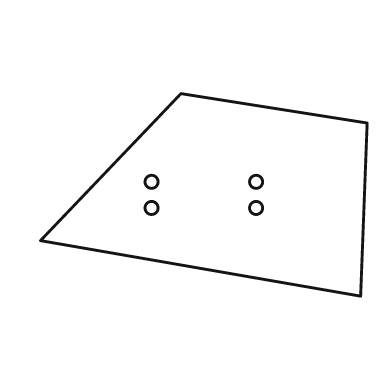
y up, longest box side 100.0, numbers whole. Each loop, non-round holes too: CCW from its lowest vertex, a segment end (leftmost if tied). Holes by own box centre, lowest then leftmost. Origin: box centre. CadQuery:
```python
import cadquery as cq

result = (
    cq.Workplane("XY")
    .moveTo(48.0, -31.0)
    .lineTo(50.0, 22.0)
    .lineTo(-7.0, 31.0)
    .lineTo(-50.0, -14.0)
    .close()
    .moveTo(-16.0, -4.0)
    .circle(2.0)
    .moveTo(16.0, -4.0)
    .circle(2.0)
    .moveTo(-16.0, 4.0)
    .circle(2.0)
    .moveTo(16.0, 4.0)
    .circle(2.0)
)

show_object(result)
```